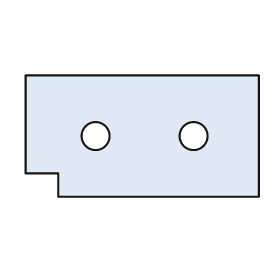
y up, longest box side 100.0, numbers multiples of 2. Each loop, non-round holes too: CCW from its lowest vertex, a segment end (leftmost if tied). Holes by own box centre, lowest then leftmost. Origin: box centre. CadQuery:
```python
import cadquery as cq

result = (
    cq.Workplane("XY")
    .moveTo(-36.0, -26.0)
    .lineTo(50.0, -26.0)
    .lineTo(50.0, 26.0)
    .lineTo(-50.0, 26.0)
    .lineTo(-50.0, -16.0)
    .lineTo(-36.0, -16.0)
    .close()
    .moveTo(-20.0, 0.0)
    .circle(6.0)
    .moveTo(22.0, 0.0)
    .circle(6.0)
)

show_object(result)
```